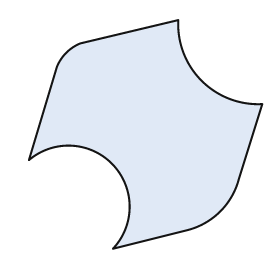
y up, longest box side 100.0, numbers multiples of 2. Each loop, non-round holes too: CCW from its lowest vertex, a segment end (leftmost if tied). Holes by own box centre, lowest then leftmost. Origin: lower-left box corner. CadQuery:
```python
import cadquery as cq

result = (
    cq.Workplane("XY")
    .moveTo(36.0, 0.0)
    .lineTo(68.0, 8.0)
    .threePointArc((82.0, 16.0), (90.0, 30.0))
    .lineTo(100.0, 62.0)
    .threePointArc((74.0, 72.0), (64.0, 98.0))
    .lineTo(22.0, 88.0)
    .threePointArc((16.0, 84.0), (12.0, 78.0))
    .lineTo(0.0, 38.0)
    .threePointArc((36.0, 36.0), (36.0, 0.0))
    .close()
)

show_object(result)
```